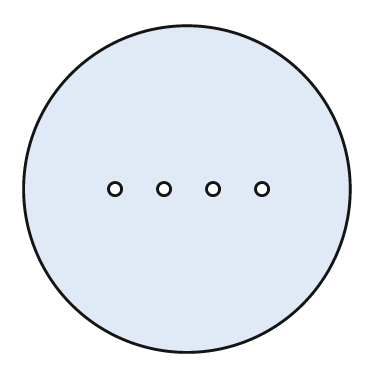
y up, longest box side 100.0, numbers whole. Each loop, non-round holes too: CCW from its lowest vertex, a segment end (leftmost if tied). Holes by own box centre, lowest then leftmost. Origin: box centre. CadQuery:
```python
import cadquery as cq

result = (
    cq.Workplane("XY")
    .moveTo(0.0, 0.0)
    .circle(50.0)
    .moveTo(-22.0, 0.0)
    .circle(2.0)
    .moveTo(-7.0, 0.0)
    .circle(2.0)
    .moveTo(8.0, 0.0)
    .circle(2.0)
    .moveTo(23.0, 0.0)
    .circle(2.0)
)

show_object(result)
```